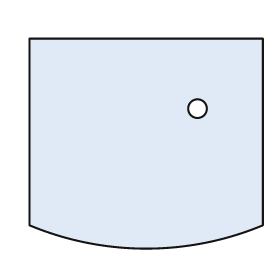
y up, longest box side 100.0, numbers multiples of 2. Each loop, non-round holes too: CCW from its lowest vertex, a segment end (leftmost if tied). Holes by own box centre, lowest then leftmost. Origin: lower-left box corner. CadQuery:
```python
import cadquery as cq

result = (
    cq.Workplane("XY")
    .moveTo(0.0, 10.0)
    .threePointArc((50.0, 0.0), (100.0, 10.0))
    .lineTo(100.0, 90.0)
    .lineTo(0.0, 90.0)
    .close()
    .moveTo(72.0, 60.0)
    .circle(4.0)
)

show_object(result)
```